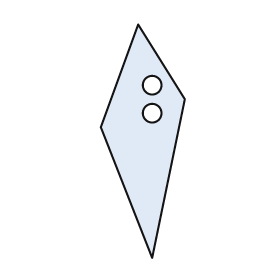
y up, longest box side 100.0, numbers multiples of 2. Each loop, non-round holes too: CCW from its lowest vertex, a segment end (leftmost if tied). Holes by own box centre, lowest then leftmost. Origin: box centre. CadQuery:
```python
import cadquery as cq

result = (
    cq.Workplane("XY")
    .moveTo(4.0, -50.0)
    .lineTo(18.0, 18.0)
    .lineTo(-2.0, 50.0)
    .lineTo(-18.0, 6.0)
    .close()
    .moveTo(4.0, 12.0)
    .circle(4.0)
    .moveTo(4.0, 24.0)
    .circle(4.0)
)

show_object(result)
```